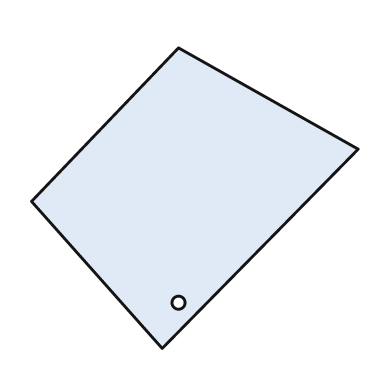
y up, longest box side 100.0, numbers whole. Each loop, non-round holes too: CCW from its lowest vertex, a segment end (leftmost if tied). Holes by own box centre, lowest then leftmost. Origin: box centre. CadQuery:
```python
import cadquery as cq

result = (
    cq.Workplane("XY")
    .moveTo(-10.0, -46.0)
    .lineTo(50.0, 15.0)
    .lineTo(-5.0, 46.0)
    .lineTo(-50.0, -1.0)
    .close()
    .moveTo(-5.0, -32.0)
    .circle(2.0)
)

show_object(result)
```